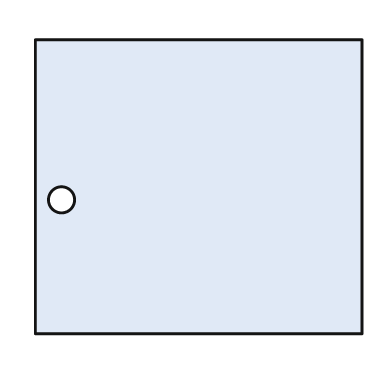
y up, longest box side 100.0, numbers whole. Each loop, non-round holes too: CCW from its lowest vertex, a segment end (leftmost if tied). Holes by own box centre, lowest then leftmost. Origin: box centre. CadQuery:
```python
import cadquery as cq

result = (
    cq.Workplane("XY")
    .moveTo(-50.0, -45.0)
    .lineTo(50.0, -45.0)
    .lineTo(50.0, 45.0)
    .lineTo(-50.0, 45.0)
    .close()
    .moveTo(-42.0, -4.0)
    .circle(4.0)
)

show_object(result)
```